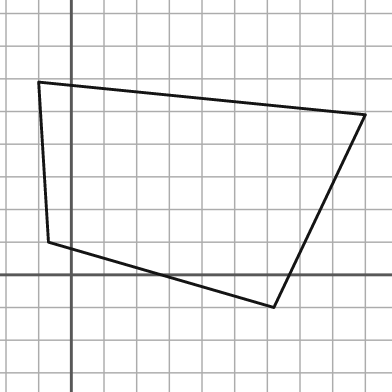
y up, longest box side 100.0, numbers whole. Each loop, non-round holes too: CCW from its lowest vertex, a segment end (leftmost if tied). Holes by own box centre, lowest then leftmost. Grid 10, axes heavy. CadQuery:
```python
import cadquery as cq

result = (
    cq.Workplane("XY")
    .moveTo(62.0, -10.0)
    .lineTo(90.0, 49.0)
    .lineTo(-10.0, 59.0)
    .lineTo(-7.0, 10.0)
    .close()
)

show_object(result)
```